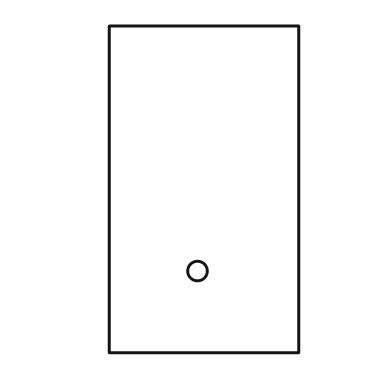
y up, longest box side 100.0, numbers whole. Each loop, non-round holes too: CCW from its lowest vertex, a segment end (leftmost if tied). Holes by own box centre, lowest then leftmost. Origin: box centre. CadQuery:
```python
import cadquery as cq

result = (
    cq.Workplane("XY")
    .moveTo(-29.0, -50.0)
    .lineTo(29.0, -50.0)
    .lineTo(29.0, 50.0)
    .lineTo(-29.0, 50.0)
    .close()
    .moveTo(-2.0, -25.0)
    .circle(3.0)
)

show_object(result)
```